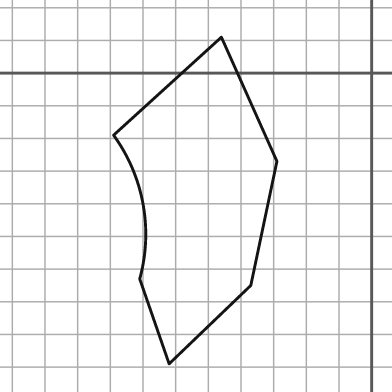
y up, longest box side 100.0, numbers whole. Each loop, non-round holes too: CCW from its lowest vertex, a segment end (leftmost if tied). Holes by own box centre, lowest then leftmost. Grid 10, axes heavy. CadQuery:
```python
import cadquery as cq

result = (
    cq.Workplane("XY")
    .moveTo(-62.0, -89.0)
    .lineTo(-37.0, -65.0)
    .lineTo(-29.0, -27.0)
    .lineTo(-46.0, 11.0)
    .lineTo(-79.0, -19.0)
    .threePointArc((-70.0, -40.0), (-71.0, -63.0))
    .close()
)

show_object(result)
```